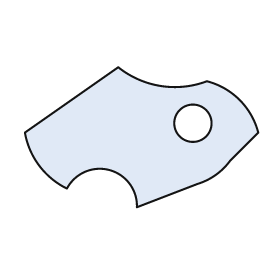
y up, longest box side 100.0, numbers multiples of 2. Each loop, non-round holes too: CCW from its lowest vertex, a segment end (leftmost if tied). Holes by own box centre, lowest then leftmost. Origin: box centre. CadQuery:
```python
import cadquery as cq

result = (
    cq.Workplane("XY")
    .moveTo(-2.0, -30.0)
    .lineTo(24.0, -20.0)
    .threePointArc((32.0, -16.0), (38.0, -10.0))
    .lineTo(50.0, 2.0)
    .threePointArc((42.0, 16.0), (28.0, 24.0))
    .threePointArc((8.0, 22.0), (-10.0, 30.0))
    .lineTo(-50.0, 2.0)
    .threePointArc((-44.0, -12.0), (-32.0, -22.0))
    .threePointArc((-14.0, -14.0), (-2.0, -30.0))
    .close()
    .moveTo(22.0, 6.0)
    .circle(8.0)
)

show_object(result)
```